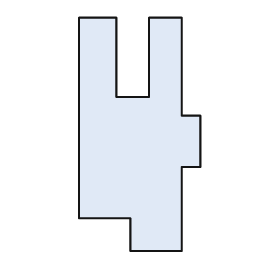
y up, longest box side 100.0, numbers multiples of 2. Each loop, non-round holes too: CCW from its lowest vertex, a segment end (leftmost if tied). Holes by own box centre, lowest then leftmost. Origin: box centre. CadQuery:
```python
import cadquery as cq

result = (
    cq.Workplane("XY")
    .moveTo(-4.0, -50.0)
    .lineTo(18.0, -50.0)
    .lineTo(18.0, -14.0)
    .lineTo(26.0, -14.0)
    .lineTo(26.0, 8.0)
    .lineTo(18.0, 8.0)
    .lineTo(18.0, 50.0)
    .lineTo(4.0, 50.0)
    .lineTo(4.0, 16.0)
    .lineTo(-10.0, 16.0)
    .lineTo(-10.0, 50.0)
    .lineTo(-26.0, 50.0)
    .lineTo(-26.0, -36.0)
    .lineTo(-4.0, -36.0)
    .close()
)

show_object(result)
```